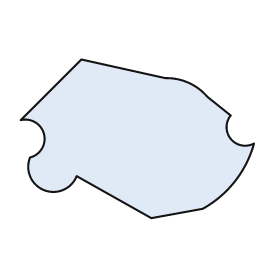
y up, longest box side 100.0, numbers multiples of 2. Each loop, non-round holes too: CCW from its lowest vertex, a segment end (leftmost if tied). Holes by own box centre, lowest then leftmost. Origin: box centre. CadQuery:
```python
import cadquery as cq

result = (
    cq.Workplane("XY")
    .moveTo(6.0, -34.0)
    .lineTo(28.0, -30.0)
    .threePointArc((42.0, -18.0), (50.0, -2.0))
    .threePointArc((40.0, 0.0), (40.0, 10.0))
    .lineTo(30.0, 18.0)
    .threePointArc((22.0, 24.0), (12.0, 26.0))
    .lineTo(-24.0, 34.0)
    .lineTo(-50.0, 8.0)
    .threePointArc((-40.0, 2.0), (-46.0, -8.0))
    .threePointArc((-40.0, -22.0), (-26.0, -16.0))
    .close()
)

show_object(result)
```